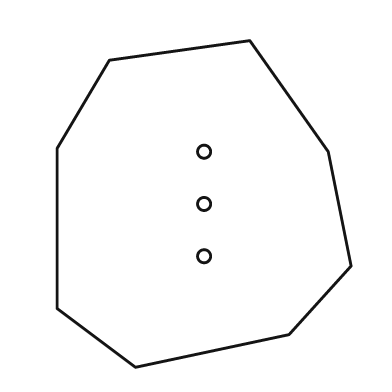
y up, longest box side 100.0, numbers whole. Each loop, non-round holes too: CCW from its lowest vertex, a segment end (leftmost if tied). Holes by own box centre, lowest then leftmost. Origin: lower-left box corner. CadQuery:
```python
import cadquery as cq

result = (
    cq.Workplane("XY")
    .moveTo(24.0, 0.0)
    .lineTo(71.0, 10.0)
    .lineTo(90.0, 31.0)
    .lineTo(83.0, 66.0)
    .lineTo(59.0, 100.0)
    .lineTo(16.0, 94.0)
    .lineTo(0.0, 67.0)
    .lineTo(0.0, 18.0)
    .close()
    .moveTo(45.0, 34.0)
    .circle(2.0)
    .moveTo(45.0, 50.0)
    .circle(2.0)
    .moveTo(45.0, 66.0)
    .circle(2.0)
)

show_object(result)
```